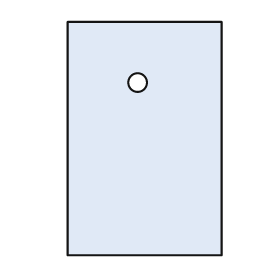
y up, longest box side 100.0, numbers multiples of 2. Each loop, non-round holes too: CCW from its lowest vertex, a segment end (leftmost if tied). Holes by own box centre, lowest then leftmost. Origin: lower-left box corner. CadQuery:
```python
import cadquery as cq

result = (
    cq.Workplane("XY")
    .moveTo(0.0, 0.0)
    .lineTo(66.0, 0.0)
    .lineTo(66.0, 100.0)
    .lineTo(0.0, 100.0)
    .close()
    .moveTo(30.0, 74.0)
    .circle(4.0)
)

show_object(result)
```